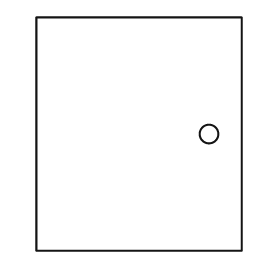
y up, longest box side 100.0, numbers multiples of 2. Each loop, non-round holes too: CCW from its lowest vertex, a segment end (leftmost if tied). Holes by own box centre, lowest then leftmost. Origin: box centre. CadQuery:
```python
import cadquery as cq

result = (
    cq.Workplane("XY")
    .moveTo(-44.0, -50.0)
    .lineTo(44.0, -50.0)
    .lineTo(44.0, 50.0)
    .lineTo(-44.0, 50.0)
    .close()
    .moveTo(30.0, 0.0)
    .circle(4.0)
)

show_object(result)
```